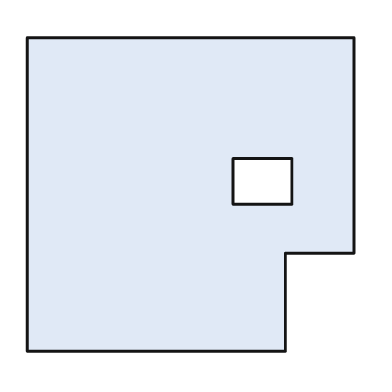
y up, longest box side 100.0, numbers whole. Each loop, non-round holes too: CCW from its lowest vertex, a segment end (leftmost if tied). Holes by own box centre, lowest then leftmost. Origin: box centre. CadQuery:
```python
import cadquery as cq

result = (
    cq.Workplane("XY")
    .moveTo(-50.0, -48.0)
    .lineTo(29.0, -48.0)
    .lineTo(29.0, -18.0)
    .lineTo(50.0, -18.0)
    .lineTo(50.0, 48.0)
    .lineTo(-50.0, 48.0)
    .close()
    .moveTo(13.0, -3.0)
    .lineTo(31.0, -3.0)
    .lineTo(31.0, 11.0)
    .lineTo(13.0, 11.0)
    .close()
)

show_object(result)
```